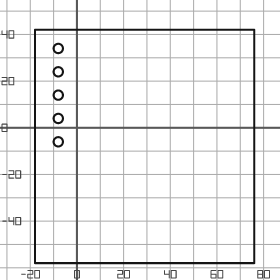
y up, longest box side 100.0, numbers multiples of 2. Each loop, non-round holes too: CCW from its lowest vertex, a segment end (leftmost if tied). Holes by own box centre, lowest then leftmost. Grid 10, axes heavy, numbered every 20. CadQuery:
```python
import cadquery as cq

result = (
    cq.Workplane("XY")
    .moveTo(-18.0, -58.0)
    .lineTo(76.0, -58.0)
    .lineTo(76.0, 42.0)
    .lineTo(-18.0, 42.0)
    .close()
    .moveTo(-8.0, -6.0)
    .circle(2.0)
    .moveTo(-8.0, 4.0)
    .circle(2.0)
    .moveTo(-8.0, 14.0)
    .circle(2.0)
    .moveTo(-8.0, 24.0)
    .circle(2.0)
    .moveTo(-8.0, 34.0)
    .circle(2.0)
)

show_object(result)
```